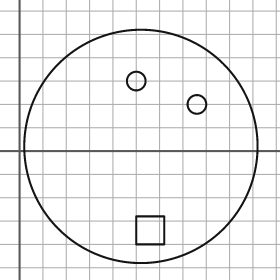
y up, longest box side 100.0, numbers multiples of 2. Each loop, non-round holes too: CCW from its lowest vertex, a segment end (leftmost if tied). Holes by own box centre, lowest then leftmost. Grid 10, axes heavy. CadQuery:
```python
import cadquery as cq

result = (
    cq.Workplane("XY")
    .moveTo(52.0, 2.0)
    .circle(50.0)
    .moveTo(50.0, -40.0)
    .lineTo(62.0, -40.0)
    .lineTo(62.0, -28.0)
    .lineTo(50.0, -28.0)
    .close()
    .moveTo(76.0, 20.0)
    .circle(4.0)
    .moveTo(50.0, 30.0)
    .circle(4.0)
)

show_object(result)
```